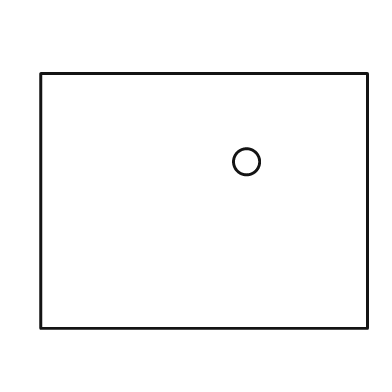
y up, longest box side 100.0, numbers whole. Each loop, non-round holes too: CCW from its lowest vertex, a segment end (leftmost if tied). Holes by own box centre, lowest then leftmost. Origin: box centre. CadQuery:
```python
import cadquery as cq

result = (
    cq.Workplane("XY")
    .moveTo(-50.0, -39.0)
    .lineTo(50.0, -39.0)
    .lineTo(50.0, 39.0)
    .lineTo(-50.0, 39.0)
    .close()
    .moveTo(13.0, 12.0)
    .circle(4.0)
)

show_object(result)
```